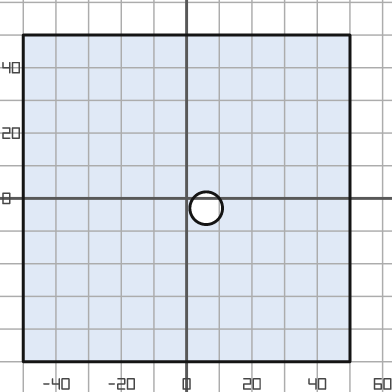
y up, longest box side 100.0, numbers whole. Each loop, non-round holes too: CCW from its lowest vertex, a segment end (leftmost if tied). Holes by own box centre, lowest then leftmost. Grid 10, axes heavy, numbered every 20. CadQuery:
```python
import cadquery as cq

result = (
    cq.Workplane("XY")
    .moveTo(-50.0, -50.0)
    .lineTo(50.0, -50.0)
    .lineTo(50.0, 50.0)
    .lineTo(-50.0, 50.0)
    .close()
    .moveTo(6.0, -3.0)
    .circle(5.0)
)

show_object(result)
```